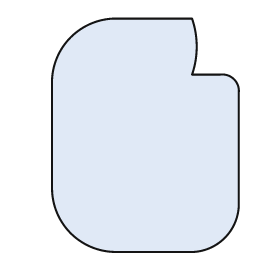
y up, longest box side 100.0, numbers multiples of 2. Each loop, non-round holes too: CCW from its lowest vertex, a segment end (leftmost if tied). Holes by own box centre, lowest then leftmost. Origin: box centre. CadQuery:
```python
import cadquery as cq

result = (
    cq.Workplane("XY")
    .moveTo(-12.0, -50.0)
    .lineTo(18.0, -50.0)
    .threePointArc((34.0, -44.0), (40.0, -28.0))
    .lineTo(40.0, 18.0)
    .threePointArc((38.0, 24.0), (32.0, 26.0))
    .lineTo(20.0, 26.0)
    .threePointArc((22.0, 38.0), (20.0, 50.0))
    .lineTo(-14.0, 50.0)
    .threePointArc((-32.0, 42.0), (-40.0, 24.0))
    .lineTo(-40.0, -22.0)
    .threePointArc((-32.0, -42.0), (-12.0, -50.0))
    .close()
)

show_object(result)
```